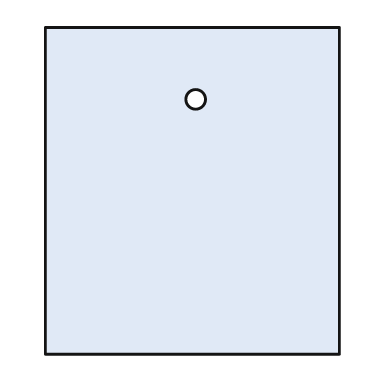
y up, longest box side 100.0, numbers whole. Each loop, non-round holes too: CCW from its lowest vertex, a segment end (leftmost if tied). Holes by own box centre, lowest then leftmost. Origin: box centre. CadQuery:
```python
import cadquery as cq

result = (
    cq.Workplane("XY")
    .moveTo(-45.0, -50.0)
    .lineTo(45.0, -50.0)
    .lineTo(45.0, 50.0)
    .lineTo(-45.0, 50.0)
    .close()
    .moveTo(1.0, 28.0)
    .circle(3.0)
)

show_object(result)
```